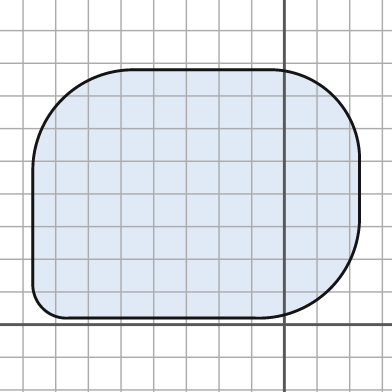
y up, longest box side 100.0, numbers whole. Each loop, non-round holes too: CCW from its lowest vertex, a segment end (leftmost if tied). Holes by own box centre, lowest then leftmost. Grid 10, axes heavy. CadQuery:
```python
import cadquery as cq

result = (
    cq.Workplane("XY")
    .moveTo(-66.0, 2.0)
    .lineTo(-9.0, 2.0)
    .threePointArc((14.0, 11.0), (23.0, 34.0))
    .lineTo(23.0, 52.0)
    .threePointArc((15.0, 70.0), (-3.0, 78.0))
    .lineTo(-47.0, 78.0)
    .threePointArc((-68.0, 69.0), (-77.0, 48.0))
    .lineTo(-77.0, 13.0)
    .threePointArc((-74.0, 5.0), (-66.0, 2.0))
    .close()
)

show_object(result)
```